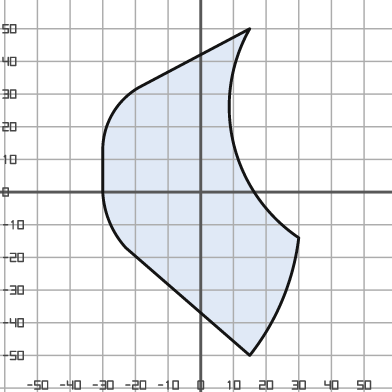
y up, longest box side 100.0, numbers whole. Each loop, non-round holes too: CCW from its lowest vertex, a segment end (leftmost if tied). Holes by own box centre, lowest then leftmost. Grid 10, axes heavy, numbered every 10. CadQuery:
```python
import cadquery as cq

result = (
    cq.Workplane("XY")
    .moveTo(15.0, -50.0)
    .threePointArc((25.0, -33.0), (30.0, -14.0))
    .threePointArc((10.0, 15.0), (15.0, 50.0))
    .lineTo(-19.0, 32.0)
    .threePointArc((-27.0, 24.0), (-30.0, 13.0))
    .lineTo(-30.0, 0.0)
    .threePointArc((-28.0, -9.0), (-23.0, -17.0))
    .close()
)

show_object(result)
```